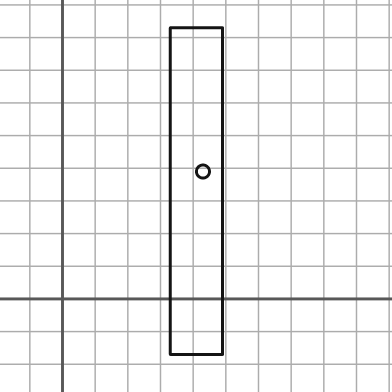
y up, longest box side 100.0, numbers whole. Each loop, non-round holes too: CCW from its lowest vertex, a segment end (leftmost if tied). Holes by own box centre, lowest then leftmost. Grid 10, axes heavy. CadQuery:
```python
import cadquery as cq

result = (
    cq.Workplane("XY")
    .moveTo(33.0, -17.0)
    .lineTo(49.0, -17.0)
    .lineTo(49.0, 83.0)
    .lineTo(33.0, 83.0)
    .close()
    .moveTo(43.0, 39.0)
    .circle(2.0)
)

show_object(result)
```